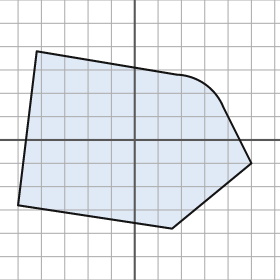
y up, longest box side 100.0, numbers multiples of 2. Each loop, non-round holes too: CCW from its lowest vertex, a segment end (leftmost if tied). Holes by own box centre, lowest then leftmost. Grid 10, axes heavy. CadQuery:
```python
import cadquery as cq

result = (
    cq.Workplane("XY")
    .moveTo(16.0, -38.0)
    .lineTo(50.0, -10.0)
    .lineTo(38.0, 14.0)
    .threePointArc((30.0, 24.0), (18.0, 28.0))
    .lineTo(-42.0, 38.0)
    .lineTo(-50.0, -28.0)
    .close()
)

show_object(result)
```